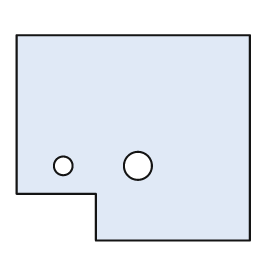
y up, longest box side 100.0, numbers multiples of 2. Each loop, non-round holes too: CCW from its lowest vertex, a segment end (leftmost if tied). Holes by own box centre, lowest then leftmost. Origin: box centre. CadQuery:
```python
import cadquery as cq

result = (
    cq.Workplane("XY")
    .moveTo(-16.0, -44.0)
    .lineTo(50.0, -44.0)
    .lineTo(50.0, 44.0)
    .lineTo(-50.0, 44.0)
    .lineTo(-50.0, -24.0)
    .lineTo(-16.0, -24.0)
    .close()
    .moveTo(-30.0, -12.0)
    .circle(4.0)
    .moveTo(2.0, -12.0)
    .circle(6.0)
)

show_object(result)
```